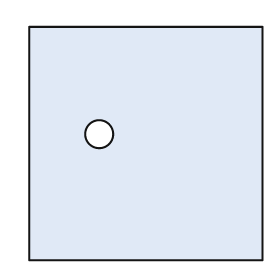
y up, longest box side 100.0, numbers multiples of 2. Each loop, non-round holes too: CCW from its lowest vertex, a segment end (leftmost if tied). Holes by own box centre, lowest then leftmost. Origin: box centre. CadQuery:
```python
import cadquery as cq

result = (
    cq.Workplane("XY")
    .moveTo(-50.0, -50.0)
    .lineTo(50.0, -50.0)
    .lineTo(50.0, 50.0)
    .lineTo(-50.0, 50.0)
    .close()
    .moveTo(-20.0, 4.0)
    .circle(6.0)
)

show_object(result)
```